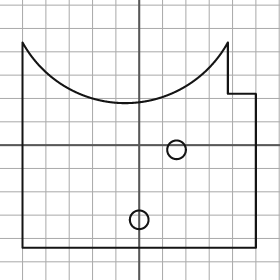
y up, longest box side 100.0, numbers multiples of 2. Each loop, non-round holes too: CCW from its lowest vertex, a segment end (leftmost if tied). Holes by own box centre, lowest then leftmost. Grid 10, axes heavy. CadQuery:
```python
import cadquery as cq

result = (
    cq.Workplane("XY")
    .moveTo(-50.0, -44.0)
    .lineTo(50.0, -44.0)
    .lineTo(50.0, 22.0)
    .lineTo(38.0, 22.0)
    .lineTo(38.0, 44.0)
    .threePointArc((-6.0, 18.0), (-50.0, 44.0))
    .close()
    .moveTo(0.0, -32.0)
    .circle(4.0)
    .moveTo(16.0, -2.0)
    .circle(4.0)
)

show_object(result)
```